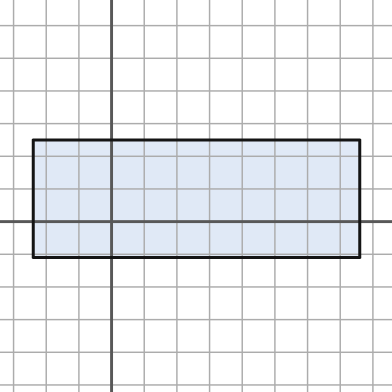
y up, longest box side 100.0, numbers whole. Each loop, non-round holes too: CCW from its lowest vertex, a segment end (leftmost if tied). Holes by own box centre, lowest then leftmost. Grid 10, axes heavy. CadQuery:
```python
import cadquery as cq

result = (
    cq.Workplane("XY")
    .moveTo(-24.0, -11.0)
    .lineTo(76.0, -11.0)
    .lineTo(76.0, 25.0)
    .lineTo(-24.0, 25.0)
    .close()
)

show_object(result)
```